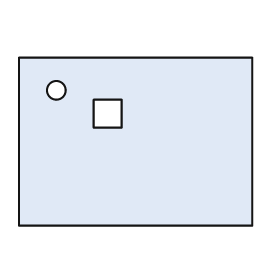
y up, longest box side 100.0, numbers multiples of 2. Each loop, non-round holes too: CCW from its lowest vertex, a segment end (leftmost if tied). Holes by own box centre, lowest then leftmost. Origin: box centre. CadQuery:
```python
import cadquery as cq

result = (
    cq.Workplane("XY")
    .moveTo(-50.0, -36.0)
    .lineTo(50.0, -36.0)
    .lineTo(50.0, 36.0)
    .lineTo(-50.0, 36.0)
    .close()
    .moveTo(-18.0, 6.0)
    .lineTo(-6.0, 6.0)
    .lineTo(-6.0, 18.0)
    .lineTo(-18.0, 18.0)
    .close()
    .moveTo(-34.0, 22.0)
    .circle(4.0)
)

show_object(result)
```